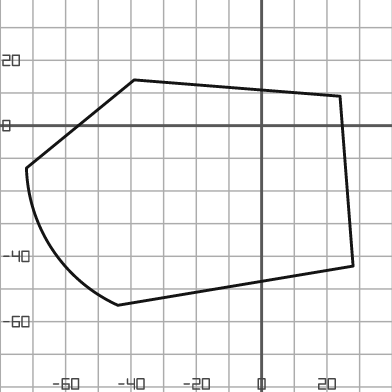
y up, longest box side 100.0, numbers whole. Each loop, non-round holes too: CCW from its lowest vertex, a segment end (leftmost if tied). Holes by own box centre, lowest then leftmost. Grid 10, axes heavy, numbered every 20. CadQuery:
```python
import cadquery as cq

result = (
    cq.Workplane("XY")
    .moveTo(-44.0, -55.0)
    .lineTo(28.0, -43.0)
    .lineTo(24.0, 9.0)
    .lineTo(-39.0, 14.0)
    .lineTo(-72.0, -13.0)
    .threePointArc((-64.0, -38.0), (-44.0, -55.0))
    .close()
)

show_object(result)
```